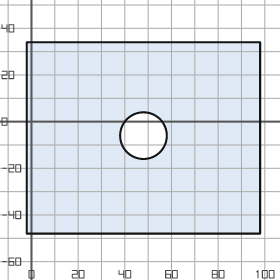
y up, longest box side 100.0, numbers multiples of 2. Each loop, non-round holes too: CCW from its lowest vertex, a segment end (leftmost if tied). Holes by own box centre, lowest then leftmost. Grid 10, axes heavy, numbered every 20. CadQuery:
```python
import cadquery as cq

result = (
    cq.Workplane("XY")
    .moveTo(-2.0, -48.0)
    .lineTo(98.0, -48.0)
    .lineTo(98.0, 34.0)
    .lineTo(-2.0, 34.0)
    .close()
    .moveTo(48.0, -6.0)
    .circle(10.0)
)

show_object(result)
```